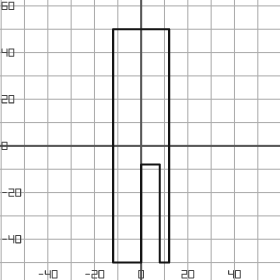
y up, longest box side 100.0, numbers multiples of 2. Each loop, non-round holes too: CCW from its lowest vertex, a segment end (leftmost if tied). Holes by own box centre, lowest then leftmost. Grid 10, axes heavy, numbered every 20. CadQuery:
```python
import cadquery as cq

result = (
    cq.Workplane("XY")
    .moveTo(-12.0, -50.0)
    .lineTo(0.0, -50.0)
    .lineTo(0.0, -8.0)
    .lineTo(8.0, -8.0)
    .lineTo(8.0, -50.0)
    .lineTo(12.0, -50.0)
    .lineTo(12.0, 50.0)
    .lineTo(-12.0, 50.0)
    .close()
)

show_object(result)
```